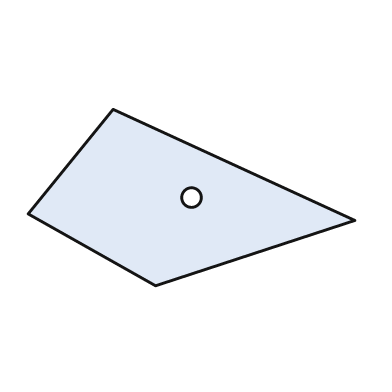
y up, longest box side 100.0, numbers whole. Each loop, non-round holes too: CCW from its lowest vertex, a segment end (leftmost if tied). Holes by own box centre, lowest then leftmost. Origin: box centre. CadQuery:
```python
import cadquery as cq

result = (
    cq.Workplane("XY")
    .moveTo(-11.0, -27.0)
    .lineTo(50.0, -7.0)
    .lineTo(-24.0, 27.0)
    .lineTo(-50.0, -5.0)
    .close()
    .moveTo(0.0, 0.0)
    .circle(3.0)
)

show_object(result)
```